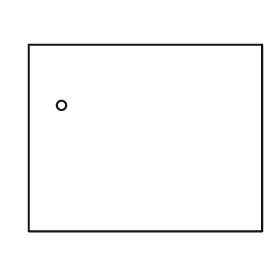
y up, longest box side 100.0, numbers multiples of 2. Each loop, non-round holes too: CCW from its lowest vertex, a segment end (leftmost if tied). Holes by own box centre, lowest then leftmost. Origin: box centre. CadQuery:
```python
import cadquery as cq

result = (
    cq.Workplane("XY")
    .moveTo(-50.0, -40.0)
    .lineTo(50.0, -40.0)
    .lineTo(50.0, 40.0)
    .lineTo(-50.0, 40.0)
    .close()
    .moveTo(-36.0, 14.0)
    .circle(2.0)
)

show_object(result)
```